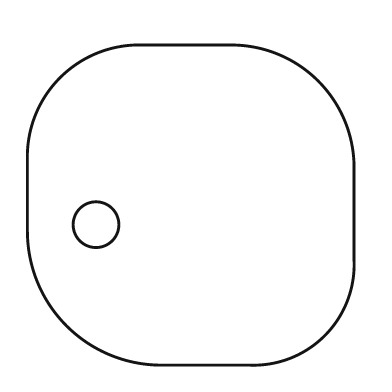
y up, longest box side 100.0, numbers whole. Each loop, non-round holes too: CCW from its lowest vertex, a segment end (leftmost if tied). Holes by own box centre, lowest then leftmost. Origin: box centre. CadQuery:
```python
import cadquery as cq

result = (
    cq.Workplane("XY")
    .moveTo(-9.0, -49.0)
    .lineTo(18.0, -49.0)
    .threePointArc((41.0, -40.0), (50.0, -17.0))
    .lineTo(50.0, 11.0)
    .threePointArc((39.0, 38.0), (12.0, 49.0))
    .lineTo(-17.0, 49.0)
    .threePointArc((-40.0, 39.0), (-50.0, 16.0))
    .lineTo(-50.0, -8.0)
    .threePointArc((-38.0, -37.0), (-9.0, -49.0))
    .close()
    .moveTo(-29.0, -6.0)
    .circle(7.0)
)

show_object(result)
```